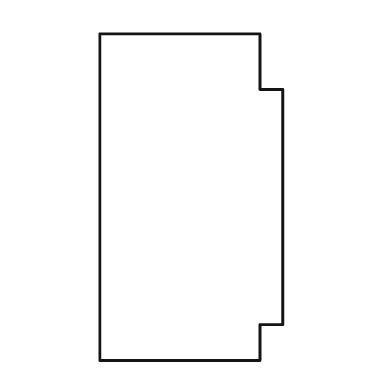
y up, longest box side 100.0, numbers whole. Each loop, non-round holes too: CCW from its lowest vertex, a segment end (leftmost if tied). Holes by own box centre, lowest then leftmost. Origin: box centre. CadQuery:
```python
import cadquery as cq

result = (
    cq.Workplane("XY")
    .moveTo(-28.0, -50.0)
    .lineTo(21.0, -50.0)
    .lineTo(21.0, -39.0)
    .lineTo(28.0, -39.0)
    .lineTo(28.0, 33.0)
    .lineTo(21.0, 33.0)
    .lineTo(21.0, 50.0)
    .lineTo(-28.0, 50.0)
    .close()
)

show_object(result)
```